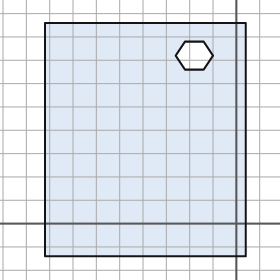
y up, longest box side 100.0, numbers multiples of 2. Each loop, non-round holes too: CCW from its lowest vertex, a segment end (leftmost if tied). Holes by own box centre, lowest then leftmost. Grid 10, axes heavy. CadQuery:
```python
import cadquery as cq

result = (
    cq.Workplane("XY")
    .moveTo(-82.0, -14.0)
    .lineTo(4.0, -14.0)
    .lineTo(4.0, 86.0)
    .lineTo(-82.0, 86.0)
    .close()
    .moveTo(-22.0, 66.0)
    .lineTo(-14.0, 66.0)
    .lineTo(-10.0, 72.0)
    .lineTo(-14.0, 78.0)
    .lineTo(-22.0, 78.0)
    .lineTo(-26.0, 72.0)
    .close()
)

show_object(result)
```